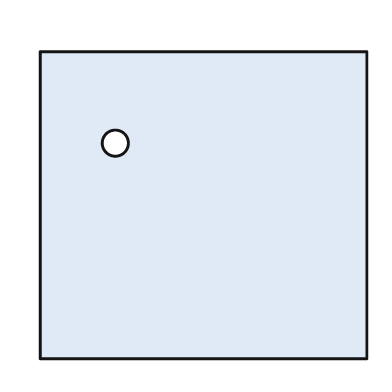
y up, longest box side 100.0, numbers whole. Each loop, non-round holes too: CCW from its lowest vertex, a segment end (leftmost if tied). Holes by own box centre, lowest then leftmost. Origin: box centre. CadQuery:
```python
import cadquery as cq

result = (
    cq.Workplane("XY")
    .moveTo(-50.0, -47.0)
    .lineTo(50.0, -47.0)
    .lineTo(50.0, 47.0)
    .lineTo(-50.0, 47.0)
    .close()
    .moveTo(-27.0, 19.0)
    .circle(4.0)
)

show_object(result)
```